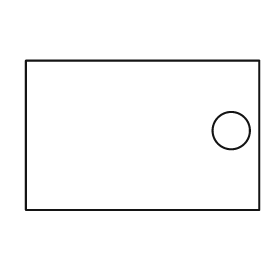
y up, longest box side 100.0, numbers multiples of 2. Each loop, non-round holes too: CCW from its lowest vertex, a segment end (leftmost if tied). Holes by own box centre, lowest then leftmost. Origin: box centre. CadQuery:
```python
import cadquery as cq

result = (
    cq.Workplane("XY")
    .moveTo(-50.0, -32.0)
    .lineTo(50.0, -32.0)
    .lineTo(50.0, 32.0)
    .lineTo(-50.0, 32.0)
    .close()
    .moveTo(38.0, 2.0)
    .circle(8.0)
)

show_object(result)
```